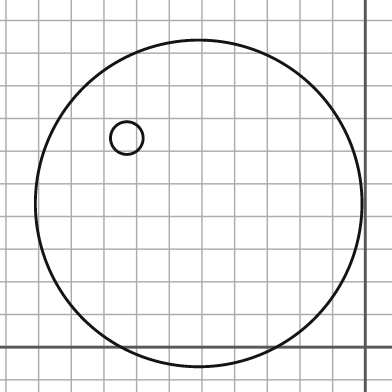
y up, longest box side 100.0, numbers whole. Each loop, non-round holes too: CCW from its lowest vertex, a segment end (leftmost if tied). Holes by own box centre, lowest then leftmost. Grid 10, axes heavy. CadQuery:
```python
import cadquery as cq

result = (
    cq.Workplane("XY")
    .moveTo(-51.0, 44.0)
    .circle(50.0)
    .moveTo(-73.0, 64.0)
    .circle(5.0)
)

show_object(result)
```